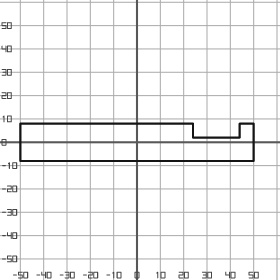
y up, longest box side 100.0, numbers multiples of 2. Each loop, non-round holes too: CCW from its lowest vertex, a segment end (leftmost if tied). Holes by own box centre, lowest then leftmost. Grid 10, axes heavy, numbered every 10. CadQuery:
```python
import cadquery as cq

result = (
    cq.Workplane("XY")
    .moveTo(-50.0, -8.0)
    .lineTo(50.0, -8.0)
    .lineTo(50.0, 8.0)
    .lineTo(44.0, 8.0)
    .lineTo(44.0, 2.0)
    .lineTo(24.0, 2.0)
    .lineTo(24.0, 8.0)
    .lineTo(-50.0, 8.0)
    .close()
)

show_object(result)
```